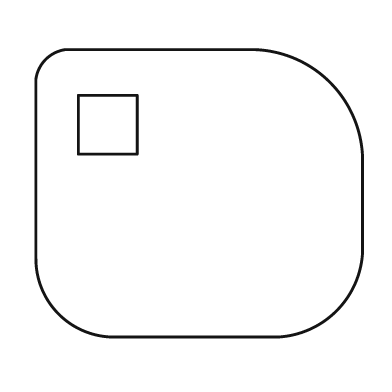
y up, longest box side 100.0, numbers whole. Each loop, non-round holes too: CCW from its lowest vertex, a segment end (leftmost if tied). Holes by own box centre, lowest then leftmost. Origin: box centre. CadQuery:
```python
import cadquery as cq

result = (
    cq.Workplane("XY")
    .moveTo(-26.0, -44.0)
    .lineTo(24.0, -44.0)
    .threePointArc((42.0, -36.0), (50.0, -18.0))
    .lineTo(50.0, 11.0)
    .threePointArc((40.0, 34.0), (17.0, 44.0))
    .lineTo(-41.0, 44.0)
    .threePointArc((-47.0, 41.0), (-50.0, 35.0))
    .lineTo(-50.0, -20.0)
    .threePointArc((-43.0, -37.0), (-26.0, -44.0))
    .close()
    .moveTo(-37.0, 12.0)
    .lineTo(-19.0, 12.0)
    .lineTo(-19.0, 30.0)
    .lineTo(-37.0, 30.0)
    .close()
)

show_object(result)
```